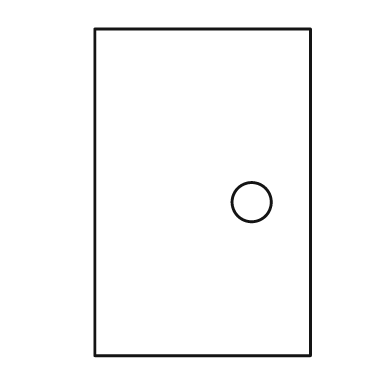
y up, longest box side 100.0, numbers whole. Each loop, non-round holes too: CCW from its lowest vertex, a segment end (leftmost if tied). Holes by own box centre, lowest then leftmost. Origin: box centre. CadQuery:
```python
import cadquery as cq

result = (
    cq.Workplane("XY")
    .moveTo(-33.0, -50.0)
    .lineTo(33.0, -50.0)
    .lineTo(33.0, 50.0)
    .lineTo(-33.0, 50.0)
    .close()
    .moveTo(15.0, -3.0)
    .circle(6.0)
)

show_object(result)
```